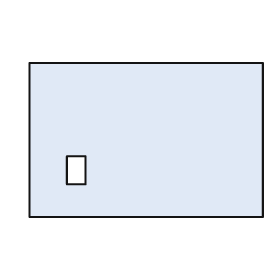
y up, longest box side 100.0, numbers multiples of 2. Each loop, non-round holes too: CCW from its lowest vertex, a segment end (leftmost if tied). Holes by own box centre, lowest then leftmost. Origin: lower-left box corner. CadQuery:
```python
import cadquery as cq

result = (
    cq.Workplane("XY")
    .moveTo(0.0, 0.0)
    .lineTo(100.0, 0.0)
    .lineTo(100.0, 66.0)
    .lineTo(0.0, 66.0)
    .close()
    .moveTo(16.0, 14.0)
    .lineTo(24.0, 14.0)
    .lineTo(24.0, 26.0)
    .lineTo(16.0, 26.0)
    .close()
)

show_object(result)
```